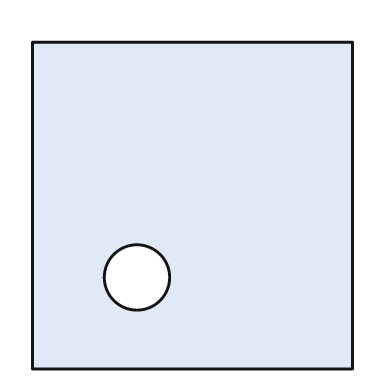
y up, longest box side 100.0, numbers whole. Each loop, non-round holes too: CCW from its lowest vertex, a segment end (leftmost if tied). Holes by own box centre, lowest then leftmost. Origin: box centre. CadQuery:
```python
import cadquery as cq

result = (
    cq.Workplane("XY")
    .moveTo(-49.0, -50.0)
    .lineTo(49.0, -50.0)
    .lineTo(49.0, 50.0)
    .lineTo(-49.0, 50.0)
    .close()
    .moveTo(-17.0, -22.0)
    .circle(10.0)
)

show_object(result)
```